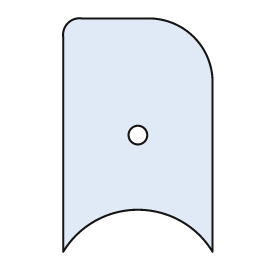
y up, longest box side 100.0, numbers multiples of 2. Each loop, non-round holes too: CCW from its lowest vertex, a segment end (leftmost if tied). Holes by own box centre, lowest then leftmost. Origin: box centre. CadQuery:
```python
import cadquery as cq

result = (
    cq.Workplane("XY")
    .moveTo(-32.0, -50.0)
    .threePointArc((0.0, -32.0), (32.0, -50.0))
    .lineTo(32.0, 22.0)
    .threePointArc((24.0, 42.0), (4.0, 50.0))
    .lineTo(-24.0, 50.0)
    .threePointArc((-30.0, 48.0), (-32.0, 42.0))
    .close()
    .moveTo(0.0, 0.0)
    .circle(4.0)
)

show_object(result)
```